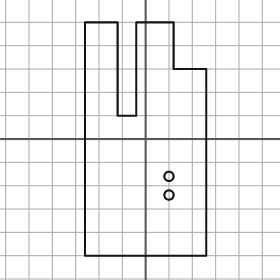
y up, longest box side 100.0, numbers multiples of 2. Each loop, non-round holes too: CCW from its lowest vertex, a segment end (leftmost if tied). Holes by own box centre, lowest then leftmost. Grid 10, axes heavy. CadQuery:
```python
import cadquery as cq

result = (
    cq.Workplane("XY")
    .moveTo(-26.0, -50.0)
    .lineTo(26.0, -50.0)
    .lineTo(26.0, 30.0)
    .lineTo(12.0, 30.0)
    .lineTo(12.0, 50.0)
    .lineTo(-4.0, 50.0)
    .lineTo(-4.0, 10.0)
    .lineTo(-12.0, 10.0)
    .lineTo(-12.0, 50.0)
    .lineTo(-26.0, 50.0)
    .close()
    .moveTo(10.0, -24.0)
    .circle(2.0)
    .moveTo(10.0, -16.0)
    .circle(2.0)
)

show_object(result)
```